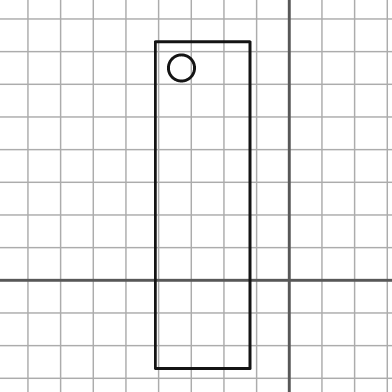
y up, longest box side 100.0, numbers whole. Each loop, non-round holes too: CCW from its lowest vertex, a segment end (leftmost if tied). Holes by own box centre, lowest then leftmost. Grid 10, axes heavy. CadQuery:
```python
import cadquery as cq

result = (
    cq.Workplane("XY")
    .moveTo(-41.0, -27.0)
    .lineTo(-12.0, -27.0)
    .lineTo(-12.0, 73.0)
    .lineTo(-41.0, 73.0)
    .close()
    .moveTo(-33.0, 65.0)
    .circle(4.0)
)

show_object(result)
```